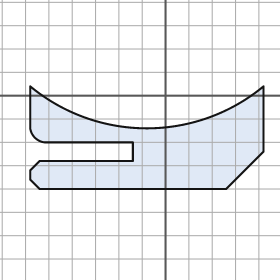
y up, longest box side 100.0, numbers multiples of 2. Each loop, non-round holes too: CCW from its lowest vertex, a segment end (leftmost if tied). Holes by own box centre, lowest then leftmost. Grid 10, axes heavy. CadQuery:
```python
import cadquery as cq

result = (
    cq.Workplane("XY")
    .moveTo(-54.0, -40.0)
    .lineTo(26.0, -40.0)
    .lineTo(42.0, -24.0)
    .lineTo(42.0, 4.0)
    .threePointArc((-8.0, -14.0), (-58.0, 4.0))
    .lineTo(-58.0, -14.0)
    .threePointArc((-56.0, -18.0), (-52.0, -20.0))
    .lineTo(-14.0, -20.0)
    .lineTo(-14.0, -28.0)
    .lineTo(-54.0, -28.0)
    .lineTo(-58.0, -32.0)
    .lineTo(-58.0, -36.0)
    .close()
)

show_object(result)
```